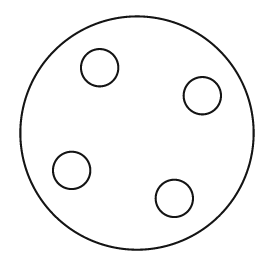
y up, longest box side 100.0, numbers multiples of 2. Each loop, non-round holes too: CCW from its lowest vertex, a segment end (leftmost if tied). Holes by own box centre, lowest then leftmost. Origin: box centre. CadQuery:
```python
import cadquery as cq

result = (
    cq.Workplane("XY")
    .moveTo(0.0, 0.0)
    .circle(50.0)
    .moveTo(16.0, -28.0)
    .circle(8.0)
    .moveTo(-28.0, -16.0)
    .circle(8.0)
    .moveTo(28.0, 16.0)
    .circle(8.0)
    .moveTo(-16.0, 28.0)
    .circle(8.0)
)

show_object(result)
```